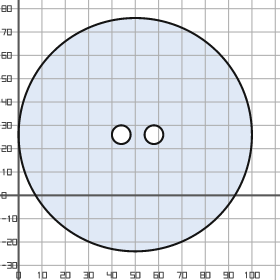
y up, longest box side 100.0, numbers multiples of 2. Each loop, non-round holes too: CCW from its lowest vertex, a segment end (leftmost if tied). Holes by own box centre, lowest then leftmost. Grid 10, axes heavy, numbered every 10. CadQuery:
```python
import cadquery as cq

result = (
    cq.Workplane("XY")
    .moveTo(50.0, 26.0)
    .circle(50.0)
    .moveTo(44.0, 26.0)
    .circle(4.0)
    .moveTo(58.0, 26.0)
    .circle(4.0)
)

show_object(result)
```